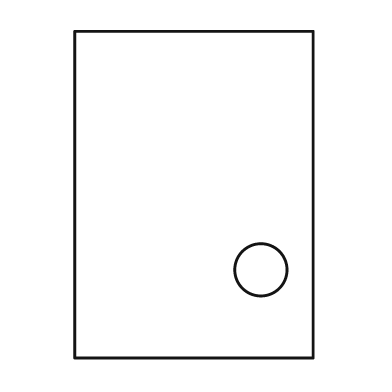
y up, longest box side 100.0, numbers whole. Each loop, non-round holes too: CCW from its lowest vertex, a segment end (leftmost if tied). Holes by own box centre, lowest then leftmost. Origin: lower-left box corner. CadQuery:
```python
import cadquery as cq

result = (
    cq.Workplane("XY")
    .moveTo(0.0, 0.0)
    .lineTo(73.0, 0.0)
    .lineTo(73.0, 100.0)
    .lineTo(0.0, 100.0)
    .close()
    .moveTo(57.0, 27.0)
    .circle(8.0)
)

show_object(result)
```